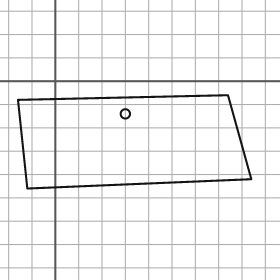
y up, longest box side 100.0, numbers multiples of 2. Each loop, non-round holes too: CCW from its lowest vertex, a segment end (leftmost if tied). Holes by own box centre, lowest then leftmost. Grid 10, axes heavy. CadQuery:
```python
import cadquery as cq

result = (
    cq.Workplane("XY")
    .moveTo(-12.0, -46.0)
    .lineTo(84.0, -42.0)
    .lineTo(74.0, -6.0)
    .lineTo(-16.0, -8.0)
    .close()
    .moveTo(30.0, -14.0)
    .circle(2.0)
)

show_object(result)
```